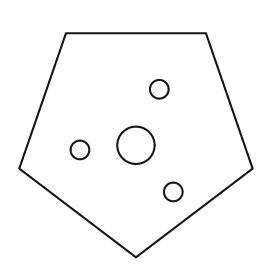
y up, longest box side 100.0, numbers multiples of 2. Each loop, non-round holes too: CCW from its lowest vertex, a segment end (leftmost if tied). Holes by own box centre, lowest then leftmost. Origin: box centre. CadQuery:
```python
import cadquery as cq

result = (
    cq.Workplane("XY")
    .moveTo(0.0, -48.0)
    .lineTo(50.0, -10.0)
    .lineTo(30.0, 48.0)
    .lineTo(-30.0, 48.0)
    .lineTo(-50.0, -10.0)
    .close()
    .moveTo(16.0, -20.0)
    .circle(4.0)
    .moveTo(-24.0, -2.0)
    .circle(4.0)
    .moveTo(0.0, 0.0)
    .circle(8.0)
    .moveTo(10.0, 24.0)
    .circle(4.0)
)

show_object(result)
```